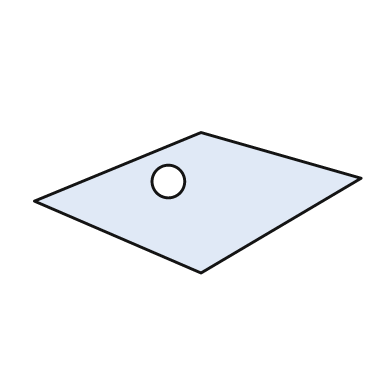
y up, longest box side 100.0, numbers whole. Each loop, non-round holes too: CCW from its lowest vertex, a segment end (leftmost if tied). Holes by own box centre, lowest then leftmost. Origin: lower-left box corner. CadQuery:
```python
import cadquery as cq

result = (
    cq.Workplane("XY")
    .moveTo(51.0, 0.0)
    .lineTo(100.0, 29.0)
    .lineTo(51.0, 43.0)
    .lineTo(0.0, 22.0)
    .close()
    .moveTo(41.0, 28.0)
    .circle(5.0)
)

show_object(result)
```